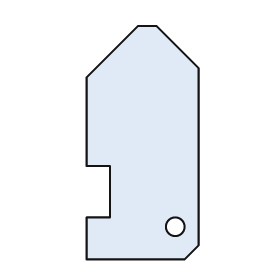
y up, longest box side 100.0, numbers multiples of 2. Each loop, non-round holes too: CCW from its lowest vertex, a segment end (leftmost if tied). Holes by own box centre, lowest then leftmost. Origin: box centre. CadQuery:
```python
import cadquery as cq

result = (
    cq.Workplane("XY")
    .moveTo(-24.0, -50.0)
    .lineTo(18.0, -50.0)
    .lineTo(24.0, -44.0)
    .lineTo(24.0, 32.0)
    .lineTo(6.0, 50.0)
    .lineTo(-2.0, 50.0)
    .lineTo(-24.0, 28.0)
    .lineTo(-24.0, -10.0)
    .lineTo(-14.0, -10.0)
    .lineTo(-14.0, -32.0)
    .lineTo(-24.0, -32.0)
    .close()
    .moveTo(14.0, -36.0)
    .circle(4.0)
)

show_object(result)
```